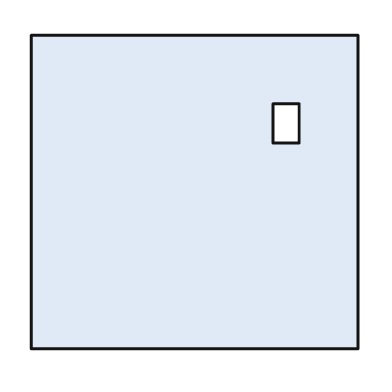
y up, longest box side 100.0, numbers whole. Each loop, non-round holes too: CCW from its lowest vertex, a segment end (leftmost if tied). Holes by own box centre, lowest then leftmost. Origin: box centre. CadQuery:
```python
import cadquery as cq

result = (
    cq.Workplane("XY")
    .moveTo(-50.0, -48.0)
    .lineTo(50.0, -48.0)
    .lineTo(50.0, 48.0)
    .lineTo(-50.0, 48.0)
    .close()
    .moveTo(24.0, 15.0)
    .lineTo(32.0, 15.0)
    .lineTo(32.0, 27.0)
    .lineTo(24.0, 27.0)
    .close()
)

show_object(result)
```